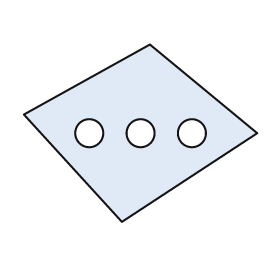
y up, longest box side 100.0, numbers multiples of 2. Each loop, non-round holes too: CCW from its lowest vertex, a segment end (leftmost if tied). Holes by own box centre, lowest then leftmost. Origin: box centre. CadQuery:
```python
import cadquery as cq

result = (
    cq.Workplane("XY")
    .moveTo(-8.0, -38.0)
    .lineTo(50.0, 0.0)
    .lineTo(4.0, 38.0)
    .lineTo(-50.0, 8.0)
    .close()
    .moveTo(-22.0, 0.0)
    .circle(6.0)
    .moveTo(0.0, 0.0)
    .circle(6.0)
    .moveTo(22.0, 0.0)
    .circle(6.0)
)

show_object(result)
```